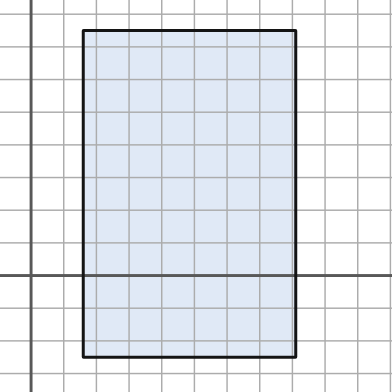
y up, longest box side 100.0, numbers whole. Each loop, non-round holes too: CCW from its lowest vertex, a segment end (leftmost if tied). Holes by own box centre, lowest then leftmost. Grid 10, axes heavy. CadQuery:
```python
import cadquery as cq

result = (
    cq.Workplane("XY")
    .moveTo(16.0, -25.0)
    .lineTo(81.0, -25.0)
    .lineTo(81.0, 75.0)
    .lineTo(16.0, 75.0)
    .close()
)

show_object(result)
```